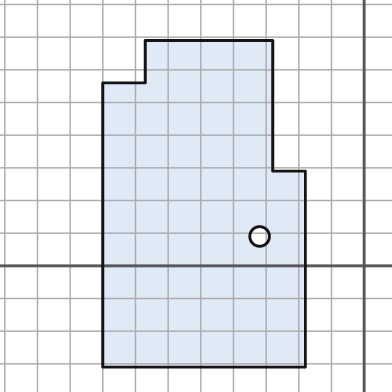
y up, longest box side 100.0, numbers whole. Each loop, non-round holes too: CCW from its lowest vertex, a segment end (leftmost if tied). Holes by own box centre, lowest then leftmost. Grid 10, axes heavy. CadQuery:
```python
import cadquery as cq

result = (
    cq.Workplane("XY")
    .moveTo(-80.0, -31.0)
    .lineTo(-18.0, -31.0)
    .lineTo(-18.0, 29.0)
    .lineTo(-28.0, 29.0)
    .lineTo(-28.0, 69.0)
    .lineTo(-67.0, 69.0)
    .lineTo(-67.0, 56.0)
    .lineTo(-80.0, 56.0)
    .close()
    .moveTo(-32.0, 9.0)
    .circle(3.0)
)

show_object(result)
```